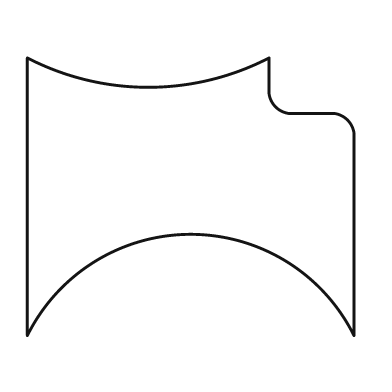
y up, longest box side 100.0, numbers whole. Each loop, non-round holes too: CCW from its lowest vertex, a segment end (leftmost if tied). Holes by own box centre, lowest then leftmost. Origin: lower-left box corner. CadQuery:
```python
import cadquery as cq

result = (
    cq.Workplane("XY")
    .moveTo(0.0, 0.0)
    .threePointArc((50.0, 31.0), (100.0, 0.0))
    .lineTo(100.0, 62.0)
    .threePointArc((98.0, 66.0), (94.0, 68.0))
    .lineTo(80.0, 68.0)
    .threePointArc((76.0, 70.0), (74.0, 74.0))
    .lineTo(74.0, 85.0)
    .threePointArc((37.0, 76.0), (0.0, 85.0))
    .close()
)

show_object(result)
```